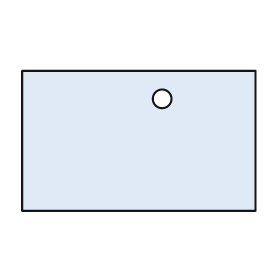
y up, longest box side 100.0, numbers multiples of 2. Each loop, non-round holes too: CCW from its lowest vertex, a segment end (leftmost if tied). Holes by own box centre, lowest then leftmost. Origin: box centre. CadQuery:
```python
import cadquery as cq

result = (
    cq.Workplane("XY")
    .moveTo(-50.0, -30.0)
    .lineTo(50.0, -30.0)
    .lineTo(50.0, 30.0)
    .lineTo(-50.0, 30.0)
    .close()
    .moveTo(10.0, 18.0)
    .circle(4.0)
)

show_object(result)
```